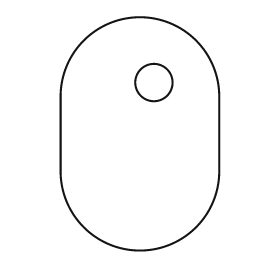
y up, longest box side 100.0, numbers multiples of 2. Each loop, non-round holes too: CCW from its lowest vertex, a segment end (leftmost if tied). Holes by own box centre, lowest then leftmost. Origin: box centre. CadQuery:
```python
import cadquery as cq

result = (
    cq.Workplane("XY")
    .moveTo(-34.0, -16.0)
    .threePointArc((0.0, -50.0), (34.0, -16.0))
    .lineTo(34.0, 16.0)
    .threePointArc((0.0, 50.0), (-34.0, 16.0))
    .close()
    .moveTo(6.0, 22.0)
    .circle(8.0)
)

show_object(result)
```